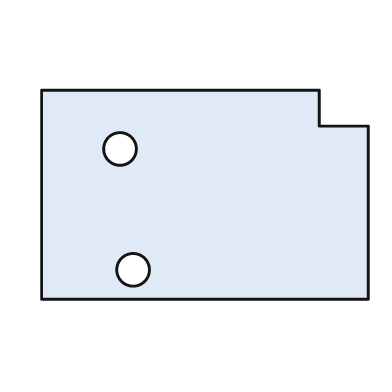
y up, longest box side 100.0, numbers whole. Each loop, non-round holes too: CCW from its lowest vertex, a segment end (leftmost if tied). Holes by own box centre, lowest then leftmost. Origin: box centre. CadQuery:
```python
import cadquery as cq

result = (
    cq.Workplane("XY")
    .moveTo(-50.0, -32.0)
    .lineTo(50.0, -32.0)
    .lineTo(50.0, 21.0)
    .lineTo(35.0, 21.0)
    .lineTo(35.0, 32.0)
    .lineTo(-50.0, 32.0)
    .close()
    .moveTo(-22.0, -23.0)
    .circle(5.0)
    .moveTo(-26.0, 14.0)
    .circle(5.0)
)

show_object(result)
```